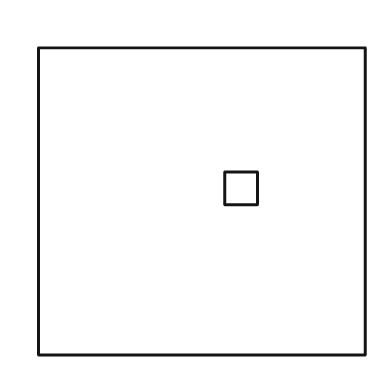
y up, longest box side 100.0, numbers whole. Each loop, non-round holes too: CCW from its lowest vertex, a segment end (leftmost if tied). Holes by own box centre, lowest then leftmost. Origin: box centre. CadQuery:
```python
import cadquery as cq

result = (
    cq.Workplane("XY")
    .moveTo(-50.0, -47.0)
    .lineTo(50.0, -47.0)
    .lineTo(50.0, 47.0)
    .lineTo(-50.0, 47.0)
    .close()
    .moveTo(7.0, -1.0)
    .lineTo(17.0, -1.0)
    .lineTo(17.0, 9.0)
    .lineTo(7.0, 9.0)
    .close()
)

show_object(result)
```